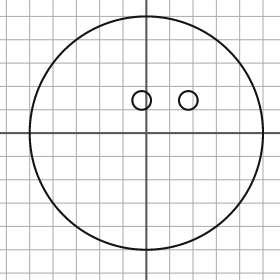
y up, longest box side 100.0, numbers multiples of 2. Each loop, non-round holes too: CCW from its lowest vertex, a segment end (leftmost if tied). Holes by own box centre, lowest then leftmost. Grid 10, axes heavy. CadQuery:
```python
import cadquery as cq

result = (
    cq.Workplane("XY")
    .moveTo(0.0, 0.0)
    .circle(50.0)
    .moveTo(-2.0, 14.0)
    .circle(4.0)
    .moveTo(18.0, 14.0)
    .circle(4.0)
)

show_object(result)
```